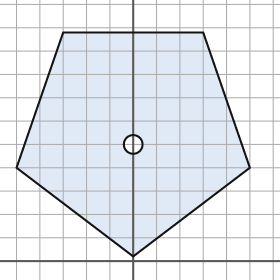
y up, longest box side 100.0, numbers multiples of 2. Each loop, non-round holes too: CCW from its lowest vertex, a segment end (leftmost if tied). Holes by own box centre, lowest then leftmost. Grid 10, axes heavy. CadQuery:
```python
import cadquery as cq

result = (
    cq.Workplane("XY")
    .moveTo(0.0, 2.0)
    .lineTo(50.0, 40.0)
    .lineTo(30.0, 98.0)
    .lineTo(-30.0, 98.0)
    .lineTo(-50.0, 40.0)
    .close()
    .moveTo(0.0, 50.0)
    .circle(4.0)
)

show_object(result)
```